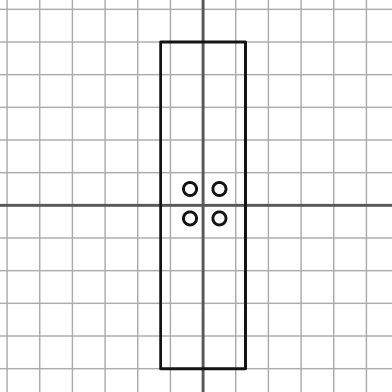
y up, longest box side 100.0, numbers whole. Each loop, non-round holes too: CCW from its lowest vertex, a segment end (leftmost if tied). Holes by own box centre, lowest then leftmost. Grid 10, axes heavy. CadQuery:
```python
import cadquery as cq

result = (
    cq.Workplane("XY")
    .moveTo(-13.0, -50.0)
    .lineTo(13.0, -50.0)
    .lineTo(13.0, 50.0)
    .lineTo(-13.0, 50.0)
    .close()
    .moveTo(-4.0, -4.0)
    .circle(2.0)
    .moveTo(5.0, -4.0)
    .circle(2.0)
    .moveTo(-4.0, 5.0)
    .circle(2.0)
    .moveTo(5.0, 5.0)
    .circle(2.0)
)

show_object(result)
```